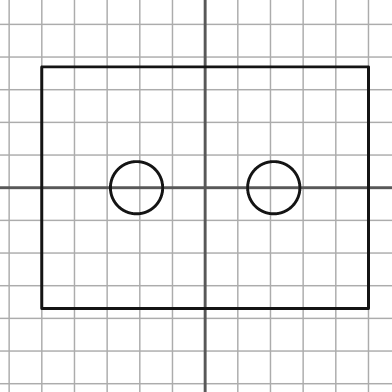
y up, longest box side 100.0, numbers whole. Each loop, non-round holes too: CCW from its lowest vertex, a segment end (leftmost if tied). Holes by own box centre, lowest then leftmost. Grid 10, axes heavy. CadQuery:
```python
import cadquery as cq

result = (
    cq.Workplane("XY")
    .moveTo(-50.0, -37.0)
    .lineTo(50.0, -37.0)
    .lineTo(50.0, 37.0)
    .lineTo(-50.0, 37.0)
    .close()
    .moveTo(-21.0, 0.0)
    .circle(8.0)
    .moveTo(21.0, 0.0)
    .circle(8.0)
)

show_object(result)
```